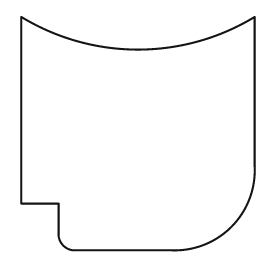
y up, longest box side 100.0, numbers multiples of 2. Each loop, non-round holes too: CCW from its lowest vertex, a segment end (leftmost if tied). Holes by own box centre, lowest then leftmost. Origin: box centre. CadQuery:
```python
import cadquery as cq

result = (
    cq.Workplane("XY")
    .moveTo(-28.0, -50.0)
    .lineTo(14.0, -50.0)
    .threePointArc((40.0, -40.0), (50.0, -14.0))
    .lineTo(50.0, 50.0)
    .threePointArc((0.0, 36.0), (-50.0, 50.0))
    .lineTo(-50.0, -30.0)
    .lineTo(-34.0, -30.0)
    .lineTo(-34.0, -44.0)
    .threePointArc((-32.0, -48.0), (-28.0, -50.0))
    .close()
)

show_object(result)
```